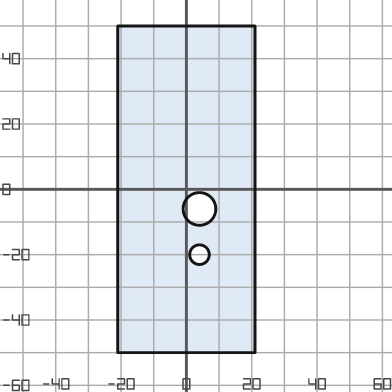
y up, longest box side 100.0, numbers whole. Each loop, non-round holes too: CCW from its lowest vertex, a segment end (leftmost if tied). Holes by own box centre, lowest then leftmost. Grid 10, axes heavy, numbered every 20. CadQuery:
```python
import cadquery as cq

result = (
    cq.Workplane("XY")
    .moveTo(-21.0, -50.0)
    .lineTo(21.0, -50.0)
    .lineTo(21.0, 50.0)
    .lineTo(-21.0, 50.0)
    .close()
    .moveTo(4.0, -20.0)
    .circle(3.0)
    .moveTo(4.0, -6.0)
    .circle(5.0)
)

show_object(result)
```